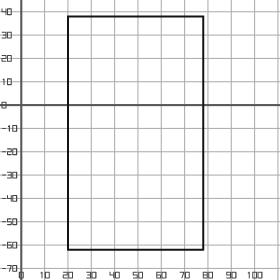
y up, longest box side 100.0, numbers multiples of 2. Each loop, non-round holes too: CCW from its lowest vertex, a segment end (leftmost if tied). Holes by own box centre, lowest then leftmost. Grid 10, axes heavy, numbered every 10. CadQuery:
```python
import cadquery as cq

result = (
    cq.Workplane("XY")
    .moveTo(20.0, -62.0)
    .lineTo(78.0, -62.0)
    .lineTo(78.0, 38.0)
    .lineTo(20.0, 38.0)
    .close()
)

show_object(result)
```